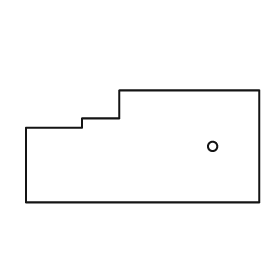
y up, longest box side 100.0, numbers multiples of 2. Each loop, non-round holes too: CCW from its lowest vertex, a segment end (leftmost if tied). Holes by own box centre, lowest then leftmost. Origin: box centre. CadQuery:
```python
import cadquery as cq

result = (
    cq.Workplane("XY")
    .moveTo(-50.0, -24.0)
    .lineTo(50.0, -24.0)
    .lineTo(50.0, 24.0)
    .lineTo(-10.0, 24.0)
    .lineTo(-10.0, 12.0)
    .lineTo(-26.0, 12.0)
    .lineTo(-26.0, 8.0)
    .lineTo(-50.0, 8.0)
    .close()
    .moveTo(30.0, 0.0)
    .circle(2.0)
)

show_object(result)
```